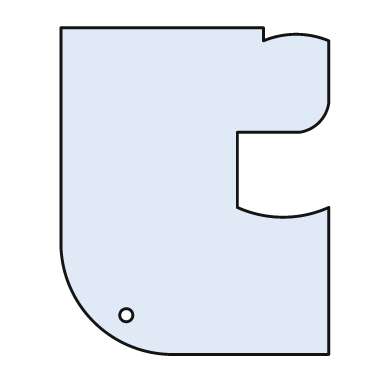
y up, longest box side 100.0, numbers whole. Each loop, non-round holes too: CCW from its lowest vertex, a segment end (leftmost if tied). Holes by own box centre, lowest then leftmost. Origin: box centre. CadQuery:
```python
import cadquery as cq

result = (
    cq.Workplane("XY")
    .moveTo(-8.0, -50.0)
    .lineTo(41.0, -50.0)
    .lineTo(41.0, -5.0)
    .threePointArc((27.0, -8.0), (13.0, -5.0))
    .lineTo(13.0, 18.0)
    .lineTo(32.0, 18.0)
    .threePointArc((38.0, 21.0), (41.0, 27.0))
    .lineTo(41.0, 46.0)
    .threePointArc((31.0, 48.0), (21.0, 46.0))
    .lineTo(21.0, 50.0)
    .lineTo(-41.0, 50.0)
    .lineTo(-41.0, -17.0)
    .threePointArc((-31.0, -40.0), (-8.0, -50.0))
    .close()
    .moveTo(-21.0, -38.0)
    .circle(2.0)
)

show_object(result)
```